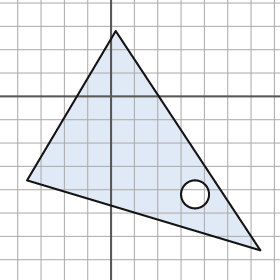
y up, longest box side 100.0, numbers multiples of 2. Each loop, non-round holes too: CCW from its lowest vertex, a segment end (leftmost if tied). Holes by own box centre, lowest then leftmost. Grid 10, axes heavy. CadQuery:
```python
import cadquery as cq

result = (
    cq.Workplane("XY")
    .moveTo(64.0, -66.0)
    .lineTo(2.0, 28.0)
    .lineTo(-36.0, -36.0)
    .close()
    .moveTo(36.0, -42.0)
    .circle(6.0)
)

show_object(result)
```